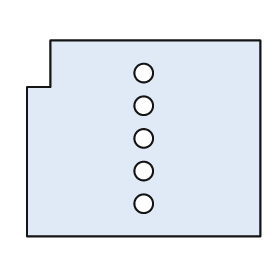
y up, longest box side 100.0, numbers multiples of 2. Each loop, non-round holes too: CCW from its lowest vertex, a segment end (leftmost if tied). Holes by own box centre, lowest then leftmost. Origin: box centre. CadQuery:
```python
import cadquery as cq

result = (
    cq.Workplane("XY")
    .moveTo(-50.0, -42.0)
    .lineTo(50.0, -42.0)
    .lineTo(50.0, 42.0)
    .lineTo(-40.0, 42.0)
    .lineTo(-40.0, 22.0)
    .lineTo(-50.0, 22.0)
    .close()
    .moveTo(0.0, -28.0)
    .circle(4.0)
    .moveTo(0.0, -14.0)
    .circle(4.0)
    .moveTo(0.0, 0.0)
    .circle(4.0)
    .moveTo(0.0, 14.0)
    .circle(4.0)
    .moveTo(0.0, 28.0)
    .circle(4.0)
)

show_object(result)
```